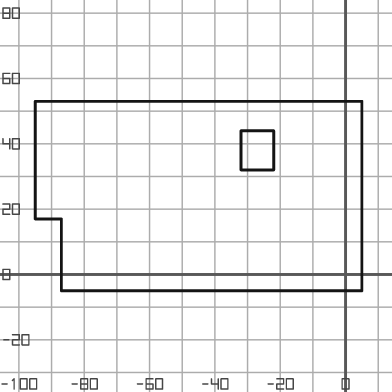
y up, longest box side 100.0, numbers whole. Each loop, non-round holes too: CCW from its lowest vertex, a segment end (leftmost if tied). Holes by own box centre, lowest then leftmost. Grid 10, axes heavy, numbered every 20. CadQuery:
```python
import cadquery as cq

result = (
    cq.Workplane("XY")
    .moveTo(-87.0, -5.0)
    .lineTo(5.0, -5.0)
    .lineTo(5.0, 53.0)
    .lineTo(-95.0, 53.0)
    .lineTo(-95.0, 17.0)
    .lineTo(-87.0, 17.0)
    .close()
    .moveTo(-32.0, 32.0)
    .lineTo(-22.0, 32.0)
    .lineTo(-22.0, 44.0)
    .lineTo(-32.0, 44.0)
    .close()
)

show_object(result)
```